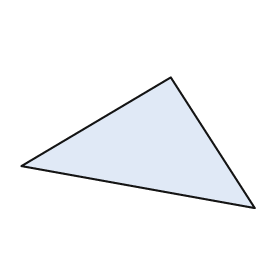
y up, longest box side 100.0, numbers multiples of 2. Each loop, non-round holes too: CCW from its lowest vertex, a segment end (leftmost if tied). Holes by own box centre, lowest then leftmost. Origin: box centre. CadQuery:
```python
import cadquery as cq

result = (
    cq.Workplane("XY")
    .moveTo(50.0, -28.0)
    .lineTo(14.0, 28.0)
    .lineTo(-50.0, -10.0)
    .close()
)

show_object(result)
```